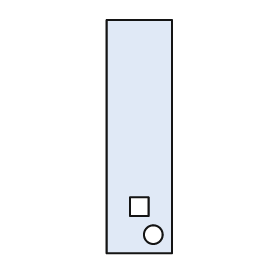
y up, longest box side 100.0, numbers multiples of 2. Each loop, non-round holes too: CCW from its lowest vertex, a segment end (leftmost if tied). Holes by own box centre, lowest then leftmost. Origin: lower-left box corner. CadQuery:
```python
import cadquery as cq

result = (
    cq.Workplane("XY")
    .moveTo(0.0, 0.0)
    .lineTo(28.0, 0.0)
    .lineTo(28.0, 100.0)
    .lineTo(0.0, 100.0)
    .close()
    .moveTo(20.0, 8.0)
    .circle(4.0)
    .moveTo(10.0, 16.0)
    .lineTo(18.0, 16.0)
    .lineTo(18.0, 24.0)
    .lineTo(10.0, 24.0)
    .close()
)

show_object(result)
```